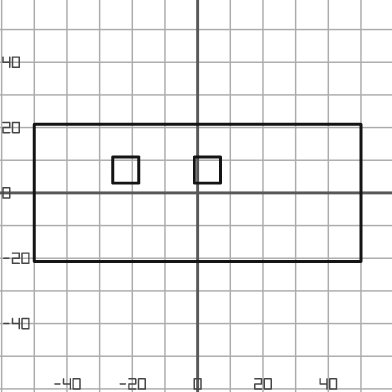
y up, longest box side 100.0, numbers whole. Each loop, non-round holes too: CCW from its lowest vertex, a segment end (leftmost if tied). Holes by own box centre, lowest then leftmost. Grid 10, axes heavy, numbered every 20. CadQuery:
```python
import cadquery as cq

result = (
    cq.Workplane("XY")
    .moveTo(-50.0, -21.0)
    .lineTo(50.0, -21.0)
    .lineTo(50.0, 21.0)
    .lineTo(-50.0, 21.0)
    .close()
    .moveTo(-26.0, 3.0)
    .lineTo(-18.0, 3.0)
    .lineTo(-18.0, 11.0)
    .lineTo(-26.0, 11.0)
    .close()
    .moveTo(-1.0, 3.0)
    .lineTo(7.0, 3.0)
    .lineTo(7.0, 11.0)
    .lineTo(-1.0, 11.0)
    .close()
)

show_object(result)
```